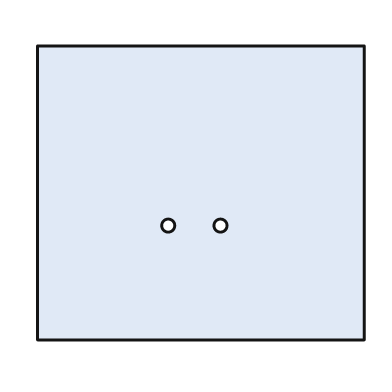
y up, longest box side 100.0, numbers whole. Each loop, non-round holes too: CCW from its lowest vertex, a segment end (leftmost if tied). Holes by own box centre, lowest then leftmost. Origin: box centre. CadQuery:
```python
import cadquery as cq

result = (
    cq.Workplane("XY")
    .moveTo(-50.0, -45.0)
    .lineTo(50.0, -45.0)
    .lineTo(50.0, 45.0)
    .lineTo(-50.0, 45.0)
    .close()
    .moveTo(-10.0, -10.0)
    .circle(2.0)
    .moveTo(6.0, -10.0)
    .circle(2.0)
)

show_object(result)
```